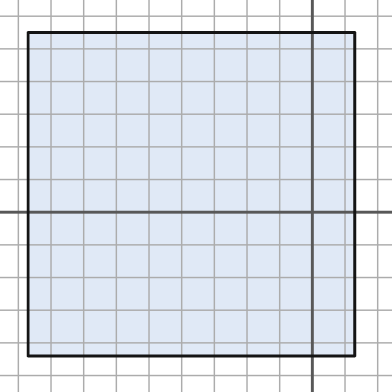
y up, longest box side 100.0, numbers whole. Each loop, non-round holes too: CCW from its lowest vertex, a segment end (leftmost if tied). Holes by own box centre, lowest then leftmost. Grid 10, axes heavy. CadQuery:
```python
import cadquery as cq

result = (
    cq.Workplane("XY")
    .moveTo(-87.0, -44.0)
    .lineTo(13.0, -44.0)
    .lineTo(13.0, 55.0)
    .lineTo(-87.0, 55.0)
    .close()
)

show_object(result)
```